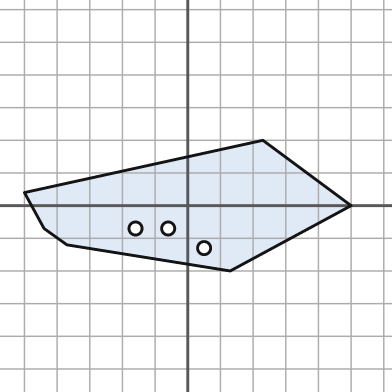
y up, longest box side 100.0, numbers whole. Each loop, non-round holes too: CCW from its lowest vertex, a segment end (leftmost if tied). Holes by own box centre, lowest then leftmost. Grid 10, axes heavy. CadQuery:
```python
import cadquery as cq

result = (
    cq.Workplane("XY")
    .moveTo(13.0, -20.0)
    .lineTo(50.0, 0.0)
    .lineTo(23.0, 20.0)
    .lineTo(-50.0, 4.0)
    .lineTo(-44.0, -7.0)
    .lineTo(-37.0, -12.0)
    .close()
    .moveTo(5.0, -13.0)
    .circle(2.0)
    .moveTo(-16.0, -7.0)
    .circle(2.0)
    .moveTo(-6.0, -7.0)
    .circle(2.0)
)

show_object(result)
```